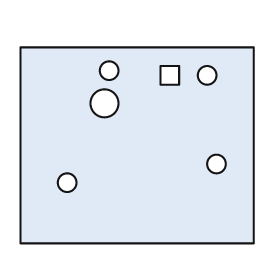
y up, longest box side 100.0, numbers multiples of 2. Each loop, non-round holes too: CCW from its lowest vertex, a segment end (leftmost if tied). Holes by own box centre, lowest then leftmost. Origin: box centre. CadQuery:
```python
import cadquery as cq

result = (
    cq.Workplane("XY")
    .moveTo(-50.0, -42.0)
    .lineTo(50.0, -42.0)
    .lineTo(50.0, 42.0)
    .lineTo(-50.0, 42.0)
    .close()
    .moveTo(-30.0, -16.0)
    .circle(4.0)
    .moveTo(34.0, -8.0)
    .circle(4.0)
    .moveTo(-14.0, 18.0)
    .circle(6.0)
    .moveTo(10.0, 26.0)
    .lineTo(18.0, 26.0)
    .lineTo(18.0, 34.0)
    .lineTo(10.0, 34.0)
    .close()
    .moveTo(30.0, 30.0)
    .circle(4.0)
    .moveTo(-12.0, 32.0)
    .circle(4.0)
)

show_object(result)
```